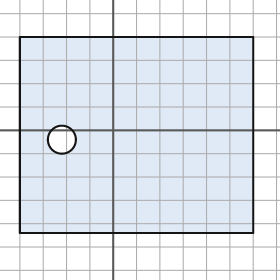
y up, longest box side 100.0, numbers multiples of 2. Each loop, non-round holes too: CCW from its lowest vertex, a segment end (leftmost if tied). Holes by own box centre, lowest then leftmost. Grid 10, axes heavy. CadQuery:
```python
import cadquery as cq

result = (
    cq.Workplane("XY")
    .moveTo(-40.0, -44.0)
    .lineTo(60.0, -44.0)
    .lineTo(60.0, 40.0)
    .lineTo(-40.0, 40.0)
    .close()
    .moveTo(-22.0, -4.0)
    .circle(6.0)
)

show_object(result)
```